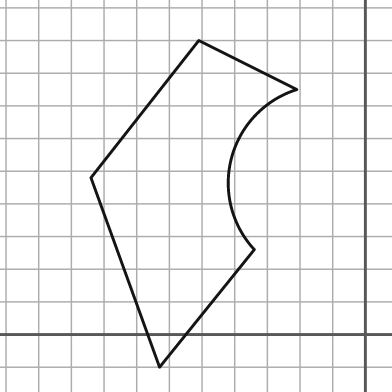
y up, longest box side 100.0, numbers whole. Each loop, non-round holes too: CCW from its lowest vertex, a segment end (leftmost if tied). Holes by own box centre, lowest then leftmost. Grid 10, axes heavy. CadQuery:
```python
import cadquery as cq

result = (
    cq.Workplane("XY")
    .moveTo(-63.0, -10.0)
    .lineTo(-34.0, 26.0)
    .threePointArc((-41.0, 54.0), (-21.0, 75.0))
    .lineTo(-51.0, 90.0)
    .lineTo(-84.0, 48.0)
    .close()
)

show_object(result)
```